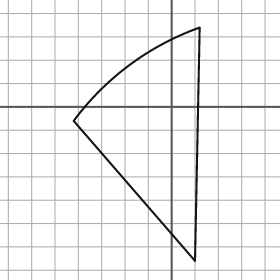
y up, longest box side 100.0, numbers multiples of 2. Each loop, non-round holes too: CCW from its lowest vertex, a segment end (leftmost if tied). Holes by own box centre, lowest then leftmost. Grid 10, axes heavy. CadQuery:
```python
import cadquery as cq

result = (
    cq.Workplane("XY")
    .moveTo(10.0, -66.0)
    .lineTo(12.0, 34.0)
    .threePointArc((-18.0, 18.0), (-42.0, -6.0))
    .close()
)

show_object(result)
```